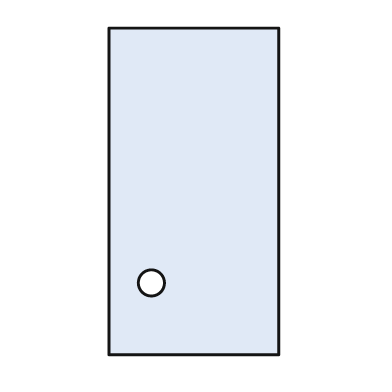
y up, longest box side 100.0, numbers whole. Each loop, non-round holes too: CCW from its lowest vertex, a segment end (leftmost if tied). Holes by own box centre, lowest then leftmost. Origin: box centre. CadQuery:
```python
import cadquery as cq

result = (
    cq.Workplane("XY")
    .moveTo(-26.0, -50.0)
    .lineTo(26.0, -50.0)
    .lineTo(26.0, 50.0)
    .lineTo(-26.0, 50.0)
    .close()
    .moveTo(-13.0, -28.0)
    .circle(4.0)
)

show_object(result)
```